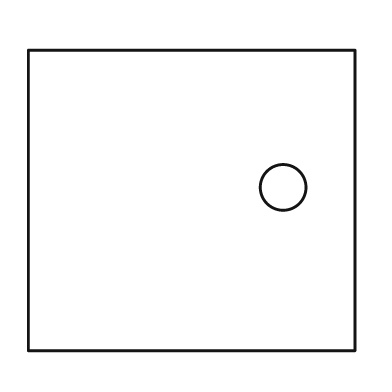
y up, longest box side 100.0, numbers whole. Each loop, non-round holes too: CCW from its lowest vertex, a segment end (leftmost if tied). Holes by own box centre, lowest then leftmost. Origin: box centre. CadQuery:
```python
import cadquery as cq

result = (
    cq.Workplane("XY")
    .moveTo(-50.0, -46.0)
    .lineTo(50.0, -46.0)
    .lineTo(50.0, 46.0)
    .lineTo(-50.0, 46.0)
    .close()
    .moveTo(28.0, 4.0)
    .circle(7.0)
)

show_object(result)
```